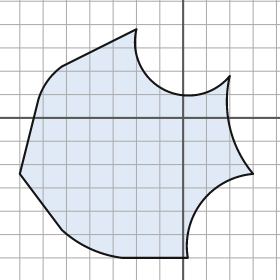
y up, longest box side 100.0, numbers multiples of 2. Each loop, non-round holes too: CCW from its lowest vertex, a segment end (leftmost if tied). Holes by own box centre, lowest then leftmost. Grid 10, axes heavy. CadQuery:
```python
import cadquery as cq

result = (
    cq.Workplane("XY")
    .moveTo(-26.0, -60.0)
    .lineTo(2.0, -60.0)
    .threePointArc((8.0, -36.0), (30.0, -24.0))
    .threePointArc((20.0, -4.0), (20.0, 18.0))
    .threePointArc((-8.0, 12.0), (-20.0, 38.0))
    .lineTo(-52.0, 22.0)
    .threePointArc((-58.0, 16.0), (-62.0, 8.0))
    .lineTo(-70.0, -24.0)
    .lineTo(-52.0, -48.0)
    .threePointArc((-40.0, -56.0), (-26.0, -60.0))
    .close()
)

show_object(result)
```